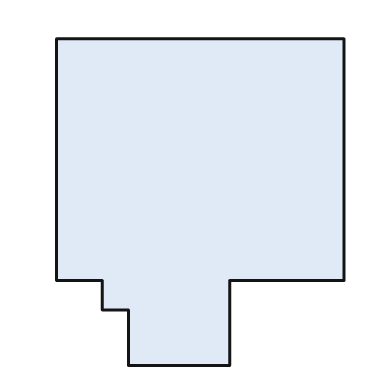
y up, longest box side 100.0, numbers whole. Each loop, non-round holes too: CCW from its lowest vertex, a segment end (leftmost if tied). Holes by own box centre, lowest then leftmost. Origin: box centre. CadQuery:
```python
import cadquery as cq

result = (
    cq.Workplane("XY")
    .moveTo(-22.0, -50.0)
    .lineTo(9.0, -50.0)
    .lineTo(9.0, -24.0)
    .lineTo(44.0, -24.0)
    .lineTo(44.0, 50.0)
    .lineTo(-44.0, 50.0)
    .lineTo(-44.0, -24.0)
    .lineTo(-30.0, -24.0)
    .lineTo(-30.0, -33.0)
    .lineTo(-22.0, -33.0)
    .close()
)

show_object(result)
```